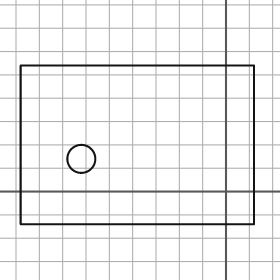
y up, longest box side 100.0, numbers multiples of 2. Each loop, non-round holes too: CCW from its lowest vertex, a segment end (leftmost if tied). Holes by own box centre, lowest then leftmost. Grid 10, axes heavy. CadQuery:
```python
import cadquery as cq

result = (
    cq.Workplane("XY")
    .moveTo(-88.0, -14.0)
    .lineTo(12.0, -14.0)
    .lineTo(12.0, 54.0)
    .lineTo(-88.0, 54.0)
    .close()
    .moveTo(-62.0, 14.0)
    .circle(6.0)
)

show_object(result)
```